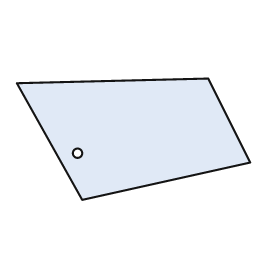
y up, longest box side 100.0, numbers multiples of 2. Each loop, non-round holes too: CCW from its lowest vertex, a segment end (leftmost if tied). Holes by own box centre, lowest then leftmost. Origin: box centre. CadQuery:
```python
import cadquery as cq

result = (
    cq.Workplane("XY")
    .moveTo(-22.0, -26.0)
    .lineTo(50.0, -10.0)
    .lineTo(32.0, 26.0)
    .lineTo(-50.0, 24.0)
    .close()
    .moveTo(-24.0, -6.0)
    .circle(2.0)
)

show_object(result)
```